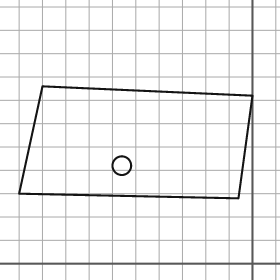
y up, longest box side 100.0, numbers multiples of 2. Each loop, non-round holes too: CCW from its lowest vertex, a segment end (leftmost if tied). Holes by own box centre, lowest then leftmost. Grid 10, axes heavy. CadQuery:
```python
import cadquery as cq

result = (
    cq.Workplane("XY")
    .moveTo(-6.0, 28.0)
    .lineTo(0.0, 72.0)
    .lineTo(-90.0, 76.0)
    .lineTo(-100.0, 30.0)
    .close()
    .moveTo(-56.0, 42.0)
    .circle(4.0)
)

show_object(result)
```